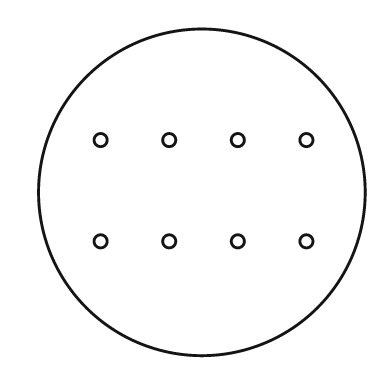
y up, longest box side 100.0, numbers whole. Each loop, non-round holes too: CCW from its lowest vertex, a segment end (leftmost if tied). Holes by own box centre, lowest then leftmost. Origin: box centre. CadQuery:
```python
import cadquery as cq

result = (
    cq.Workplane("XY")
    .moveTo(0.0, 0.0)
    .circle(50.0)
    .moveTo(-31.0, -15.0)
    .circle(2.0)
    .moveTo(-10.0, -15.0)
    .circle(2.0)
    .moveTo(11.0, -15.0)
    .circle(2.0)
    .moveTo(32.0, -15.0)
    .circle(2.0)
    .moveTo(-31.0, 16.0)
    .circle(2.0)
    .moveTo(-10.0, 16.0)
    .circle(2.0)
    .moveTo(11.0, 16.0)
    .circle(2.0)
    .moveTo(32.0, 16.0)
    .circle(2.0)
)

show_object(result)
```